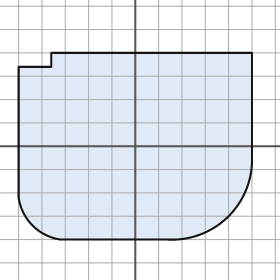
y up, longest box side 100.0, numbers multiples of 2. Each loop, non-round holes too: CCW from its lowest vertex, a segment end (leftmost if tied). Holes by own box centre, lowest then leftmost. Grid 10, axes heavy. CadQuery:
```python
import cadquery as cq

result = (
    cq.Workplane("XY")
    .moveTo(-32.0, -40.0)
    .lineTo(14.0, -40.0)
    .threePointArc((40.0, -30.0), (50.0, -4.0))
    .lineTo(50.0, 40.0)
    .lineTo(-36.0, 40.0)
    .lineTo(-36.0, 34.0)
    .lineTo(-50.0, 34.0)
    .lineTo(-50.0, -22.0)
    .threePointArc((-44.0, -34.0), (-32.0, -40.0))
    .close()
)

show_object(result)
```